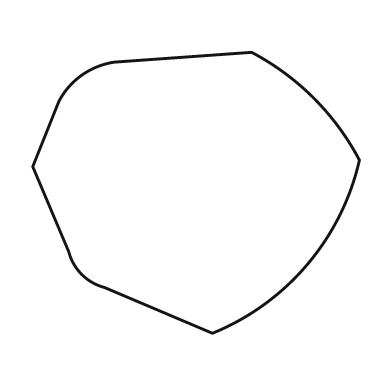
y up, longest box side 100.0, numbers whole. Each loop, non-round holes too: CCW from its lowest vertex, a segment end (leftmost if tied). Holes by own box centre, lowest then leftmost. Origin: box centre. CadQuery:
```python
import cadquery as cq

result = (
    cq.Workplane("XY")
    .moveTo(5.0, -43.0)
    .threePointArc((34.0, -22.0), (50.0, 10.0))
    .threePointArc((36.0, 29.0), (17.0, 43.0))
    .lineTo(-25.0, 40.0)
    .threePointArc((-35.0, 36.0), (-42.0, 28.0))
    .lineTo(-50.0, 8.0)
    .lineTo(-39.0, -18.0)
    .threePointArc((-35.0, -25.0), (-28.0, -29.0))
    .close()
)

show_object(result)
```